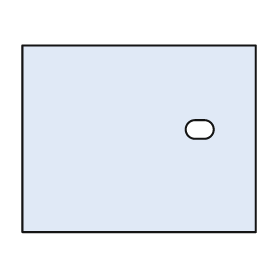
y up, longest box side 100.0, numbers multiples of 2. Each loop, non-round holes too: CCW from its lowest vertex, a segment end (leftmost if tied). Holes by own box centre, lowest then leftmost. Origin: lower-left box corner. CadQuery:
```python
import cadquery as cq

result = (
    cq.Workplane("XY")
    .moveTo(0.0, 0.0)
    .lineTo(100.0, 0.0)
    .lineTo(100.0, 80.0)
    .lineTo(0.0, 80.0)
    .close()
    .moveTo(74.0, 40.0)
    .lineTo(78.0, 40.0)
    .threePointArc((82.0, 44.0), (78.0, 48.0))
    .lineTo(74.0, 48.0)
    .threePointArc((70.0, 44.0), (74.0, 40.0))
    .close()
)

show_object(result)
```